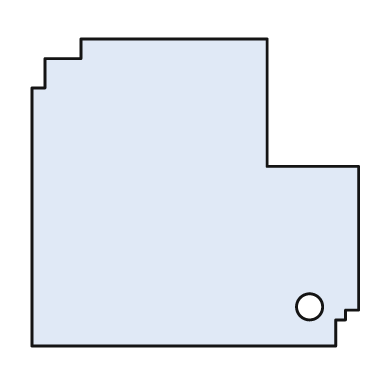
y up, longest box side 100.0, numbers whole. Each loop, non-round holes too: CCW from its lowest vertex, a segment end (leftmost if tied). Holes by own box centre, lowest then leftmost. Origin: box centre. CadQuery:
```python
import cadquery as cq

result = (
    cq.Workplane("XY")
    .moveTo(-50.0, -47.0)
    .lineTo(43.0, -47.0)
    .lineTo(43.0, -39.0)
    .lineTo(46.0, -39.0)
    .lineTo(46.0, -36.0)
    .lineTo(50.0, -36.0)
    .lineTo(50.0, 8.0)
    .lineTo(22.0, 8.0)
    .lineTo(22.0, 47.0)
    .lineTo(-35.0, 47.0)
    .lineTo(-35.0, 41.0)
    .lineTo(-46.0, 41.0)
    .lineTo(-46.0, 32.0)
    .lineTo(-50.0, 32.0)
    .close()
    .moveTo(35.0, -35.0)
    .circle(4.0)
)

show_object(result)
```